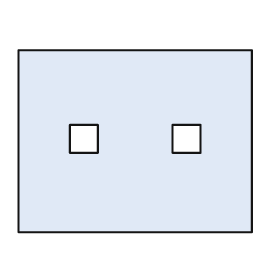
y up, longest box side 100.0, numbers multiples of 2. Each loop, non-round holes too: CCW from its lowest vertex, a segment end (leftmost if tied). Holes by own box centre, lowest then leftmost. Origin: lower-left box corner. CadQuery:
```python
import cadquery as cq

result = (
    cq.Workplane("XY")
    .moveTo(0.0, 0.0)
    .lineTo(100.0, 0.0)
    .lineTo(100.0, 78.0)
    .lineTo(0.0, 78.0)
    .close()
    .moveTo(22.0, 34.0)
    .lineTo(34.0, 34.0)
    .lineTo(34.0, 46.0)
    .lineTo(22.0, 46.0)
    .close()
    .moveTo(66.0, 34.0)
    .lineTo(78.0, 34.0)
    .lineTo(78.0, 46.0)
    .lineTo(66.0, 46.0)
    .close()
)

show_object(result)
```